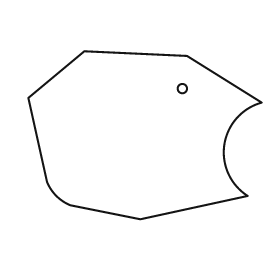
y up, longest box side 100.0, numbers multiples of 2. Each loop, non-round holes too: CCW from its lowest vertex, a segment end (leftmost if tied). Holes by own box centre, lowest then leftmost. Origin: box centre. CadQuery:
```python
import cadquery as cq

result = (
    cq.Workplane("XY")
    .moveTo(-2.0, -36.0)
    .lineTo(44.0, -26.0)
    .threePointArc((34.0, -4.0), (50.0, 14.0))
    .lineTo(18.0, 34.0)
    .lineTo(-26.0, 36.0)
    .lineTo(-50.0, 16.0)
    .lineTo(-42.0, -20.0)
    .threePointArc((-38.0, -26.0), (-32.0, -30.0))
    .close()
    .moveTo(16.0, 20.0)
    .circle(2.0)
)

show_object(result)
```